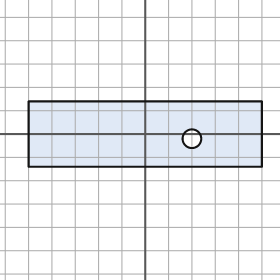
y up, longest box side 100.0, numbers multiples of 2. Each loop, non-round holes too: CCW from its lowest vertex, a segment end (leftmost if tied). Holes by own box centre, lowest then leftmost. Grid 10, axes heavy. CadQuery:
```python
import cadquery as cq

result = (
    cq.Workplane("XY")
    .moveTo(-50.0, -14.0)
    .lineTo(50.0, -14.0)
    .lineTo(50.0, 14.0)
    .lineTo(-50.0, 14.0)
    .close()
    .moveTo(20.0, -2.0)
    .circle(4.0)
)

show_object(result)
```